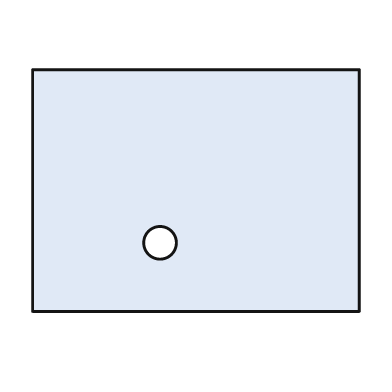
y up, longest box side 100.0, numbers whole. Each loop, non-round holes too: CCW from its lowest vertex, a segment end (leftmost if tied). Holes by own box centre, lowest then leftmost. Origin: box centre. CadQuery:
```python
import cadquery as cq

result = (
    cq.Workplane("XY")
    .moveTo(-50.0, -37.0)
    .lineTo(50.0, -37.0)
    .lineTo(50.0, 37.0)
    .lineTo(-50.0, 37.0)
    .close()
    .moveTo(-11.0, -16.0)
    .circle(5.0)
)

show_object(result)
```